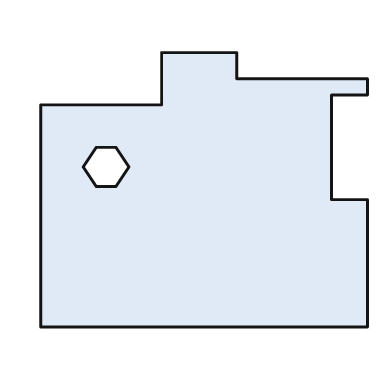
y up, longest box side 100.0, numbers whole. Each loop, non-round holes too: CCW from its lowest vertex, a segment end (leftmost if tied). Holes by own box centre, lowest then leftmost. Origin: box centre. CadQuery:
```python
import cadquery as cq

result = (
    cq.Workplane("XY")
    .moveTo(-50.0, -42.0)
    .lineTo(50.0, -42.0)
    .lineTo(50.0, -3.0)
    .lineTo(39.0, -3.0)
    .lineTo(39.0, 29.0)
    .lineTo(50.0, 29.0)
    .lineTo(50.0, 34.0)
    .lineTo(10.0, 34.0)
    .lineTo(10.0, 42.0)
    .lineTo(-13.0, 42.0)
    .lineTo(-13.0, 26.0)
    .lineTo(-50.0, 26.0)
    .close()
    .moveTo(-33.0, 1.0)
    .lineTo(-27.0, 1.0)
    .lineTo(-23.0, 7.0)
    .lineTo(-27.0, 13.0)
    .lineTo(-33.0, 13.0)
    .lineTo(-37.0, 7.0)
    .close()
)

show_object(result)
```